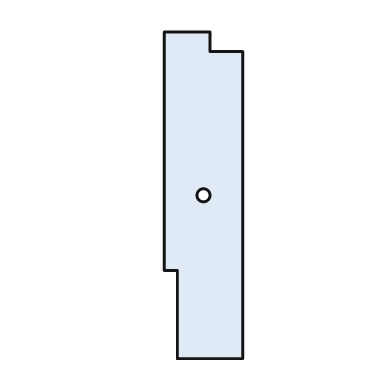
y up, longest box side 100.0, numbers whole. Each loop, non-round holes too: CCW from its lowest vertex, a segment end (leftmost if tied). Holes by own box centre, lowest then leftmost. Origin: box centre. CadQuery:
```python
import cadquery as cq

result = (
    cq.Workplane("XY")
    .moveTo(-8.0, -50.0)
    .lineTo(12.0, -50.0)
    .lineTo(12.0, 44.0)
    .lineTo(2.0, 44.0)
    .lineTo(2.0, 50.0)
    .lineTo(-12.0, 50.0)
    .lineTo(-12.0, -23.0)
    .lineTo(-8.0, -23.0)
    .close()
    .moveTo(0.0, 0.0)
    .circle(2.0)
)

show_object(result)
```